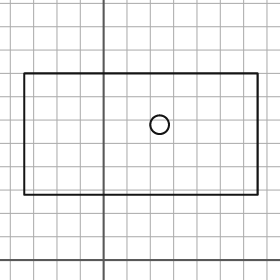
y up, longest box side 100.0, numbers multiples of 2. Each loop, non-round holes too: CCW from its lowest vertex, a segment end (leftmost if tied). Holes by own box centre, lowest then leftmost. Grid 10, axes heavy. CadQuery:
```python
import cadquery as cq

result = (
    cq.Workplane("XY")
    .moveTo(-34.0, 28.0)
    .lineTo(66.0, 28.0)
    .lineTo(66.0, 80.0)
    .lineTo(-34.0, 80.0)
    .close()
    .moveTo(24.0, 58.0)
    .circle(4.0)
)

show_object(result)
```